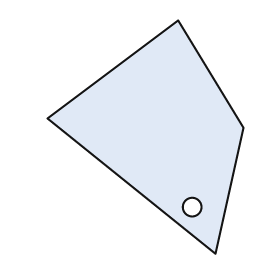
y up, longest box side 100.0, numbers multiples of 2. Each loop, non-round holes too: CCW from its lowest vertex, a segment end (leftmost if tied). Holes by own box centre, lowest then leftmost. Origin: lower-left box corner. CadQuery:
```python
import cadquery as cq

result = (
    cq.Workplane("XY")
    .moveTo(72.0, 0.0)
    .lineTo(84.0, 54.0)
    .lineTo(56.0, 100.0)
    .lineTo(0.0, 58.0)
    .close()
    .moveTo(62.0, 20.0)
    .circle(4.0)
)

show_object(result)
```